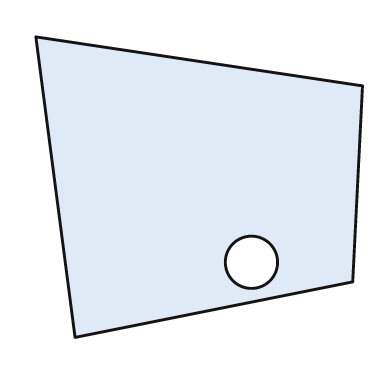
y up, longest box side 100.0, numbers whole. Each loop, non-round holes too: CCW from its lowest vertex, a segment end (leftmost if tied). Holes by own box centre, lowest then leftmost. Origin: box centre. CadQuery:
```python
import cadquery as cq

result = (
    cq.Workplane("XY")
    .moveTo(-38.0, -46.0)
    .lineTo(47.0, -29.0)
    .lineTo(50.0, 31.0)
    .lineTo(-50.0, 46.0)
    .close()
    .moveTo(16.0, -23.0)
    .circle(8.0)
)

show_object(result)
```